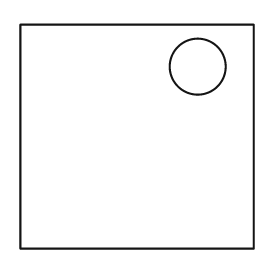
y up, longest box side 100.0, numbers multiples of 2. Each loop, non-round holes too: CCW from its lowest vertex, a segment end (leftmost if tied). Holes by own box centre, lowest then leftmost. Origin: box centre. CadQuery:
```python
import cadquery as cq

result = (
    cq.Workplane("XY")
    .moveTo(-50.0, -48.0)
    .lineTo(50.0, -48.0)
    .lineTo(50.0, 48.0)
    .lineTo(-50.0, 48.0)
    .close()
    .moveTo(26.0, 30.0)
    .circle(12.0)
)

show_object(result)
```